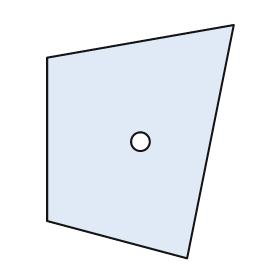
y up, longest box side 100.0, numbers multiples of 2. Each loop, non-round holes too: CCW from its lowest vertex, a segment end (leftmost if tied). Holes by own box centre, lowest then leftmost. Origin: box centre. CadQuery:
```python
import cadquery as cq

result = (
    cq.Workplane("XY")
    .moveTo(20.0, -50.0)
    .lineTo(40.0, 50.0)
    .lineTo(-40.0, 36.0)
    .lineTo(-40.0, -34.0)
    .close()
    .moveTo(0.0, 0.0)
    .circle(4.0)
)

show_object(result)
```